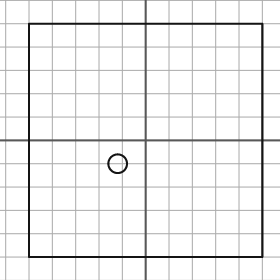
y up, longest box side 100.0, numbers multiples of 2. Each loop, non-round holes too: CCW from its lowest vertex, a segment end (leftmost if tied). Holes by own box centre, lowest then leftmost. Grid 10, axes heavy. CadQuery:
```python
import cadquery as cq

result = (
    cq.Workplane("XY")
    .moveTo(-50.0, -50.0)
    .lineTo(50.0, -50.0)
    .lineTo(50.0, 50.0)
    .lineTo(-50.0, 50.0)
    .close()
    .moveTo(-12.0, -10.0)
    .circle(4.0)
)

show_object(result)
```